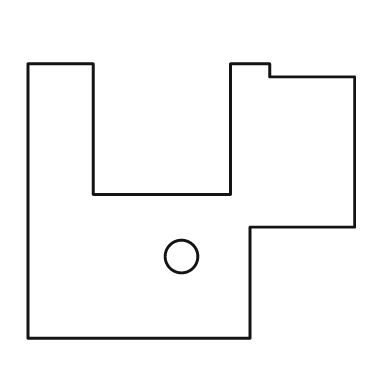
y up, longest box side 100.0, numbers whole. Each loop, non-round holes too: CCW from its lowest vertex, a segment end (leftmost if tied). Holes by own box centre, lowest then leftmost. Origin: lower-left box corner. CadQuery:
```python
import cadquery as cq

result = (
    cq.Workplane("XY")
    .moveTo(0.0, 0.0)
    .lineTo(68.0, 0.0)
    .lineTo(68.0, 34.0)
    .lineTo(100.0, 34.0)
    .lineTo(100.0, 80.0)
    .lineTo(74.0, 80.0)
    .lineTo(74.0, 84.0)
    .lineTo(62.0, 84.0)
    .lineTo(62.0, 44.0)
    .lineTo(20.0, 44.0)
    .lineTo(20.0, 84.0)
    .lineTo(0.0, 84.0)
    .close()
    .moveTo(47.0, 25.0)
    .circle(5.0)
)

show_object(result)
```